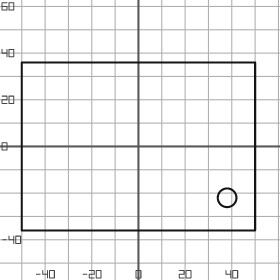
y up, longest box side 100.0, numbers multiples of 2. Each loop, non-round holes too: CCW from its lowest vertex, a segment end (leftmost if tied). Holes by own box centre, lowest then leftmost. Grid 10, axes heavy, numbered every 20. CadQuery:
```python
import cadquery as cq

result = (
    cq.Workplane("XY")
    .moveTo(-50.0, -36.0)
    .lineTo(50.0, -36.0)
    .lineTo(50.0, 36.0)
    .lineTo(-50.0, 36.0)
    .close()
    .moveTo(38.0, -22.0)
    .circle(4.0)
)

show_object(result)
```